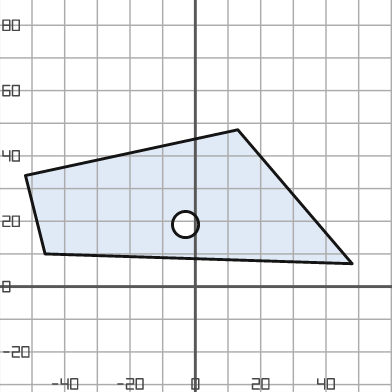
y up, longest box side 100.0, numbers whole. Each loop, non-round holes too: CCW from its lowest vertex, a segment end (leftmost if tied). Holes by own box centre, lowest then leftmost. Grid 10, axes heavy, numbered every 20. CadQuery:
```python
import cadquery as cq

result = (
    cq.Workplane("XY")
    .moveTo(48.0, 7.0)
    .lineTo(13.0, 48.0)
    .lineTo(-52.0, 34.0)
    .lineTo(-46.0, 10.0)
    .close()
    .moveTo(-3.0, 19.0)
    .circle(4.0)
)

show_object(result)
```